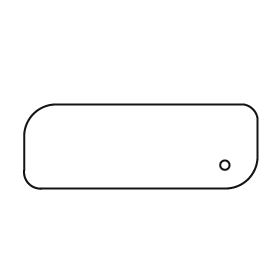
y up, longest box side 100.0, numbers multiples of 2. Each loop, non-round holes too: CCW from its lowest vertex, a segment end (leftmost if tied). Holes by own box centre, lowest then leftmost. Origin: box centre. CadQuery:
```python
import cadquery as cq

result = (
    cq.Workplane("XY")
    .moveTo(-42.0, -18.0)
    .lineTo(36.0, -18.0)
    .threePointArc((46.0, -14.0), (50.0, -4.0))
    .lineTo(50.0, 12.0)
    .threePointArc((48.0, 16.0), (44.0, 18.0))
    .lineTo(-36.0, 18.0)
    .threePointArc((-46.0, 14.0), (-50.0, 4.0))
    .lineTo(-50.0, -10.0)
    .threePointArc((-48.0, -16.0), (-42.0, -18.0))
    .close()
    .moveTo(36.0, -8.0)
    .circle(2.0)
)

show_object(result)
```